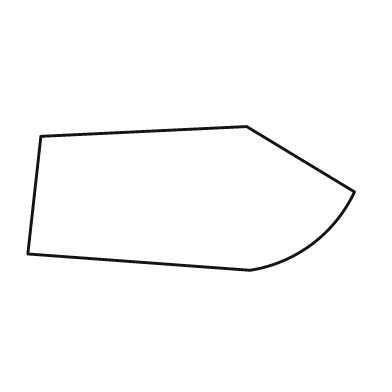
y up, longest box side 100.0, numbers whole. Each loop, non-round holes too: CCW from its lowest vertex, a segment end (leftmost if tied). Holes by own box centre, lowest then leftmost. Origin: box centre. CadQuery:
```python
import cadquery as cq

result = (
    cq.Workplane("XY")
    .moveTo(18.0, -22.0)
    .threePointArc((37.0, -14.0), (50.0, 2.0))
    .lineTo(17.0, 22.0)
    .lineTo(-46.0, 19.0)
    .lineTo(-50.0, -17.0)
    .close()
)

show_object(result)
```